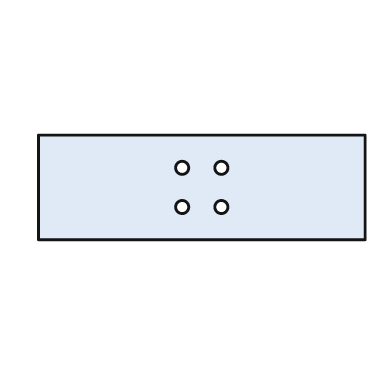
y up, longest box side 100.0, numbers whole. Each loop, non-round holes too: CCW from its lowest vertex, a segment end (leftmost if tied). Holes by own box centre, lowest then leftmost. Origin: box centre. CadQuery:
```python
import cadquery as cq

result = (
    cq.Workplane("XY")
    .moveTo(-50.0, -16.0)
    .lineTo(50.0, -16.0)
    .lineTo(50.0, 16.0)
    .lineTo(-50.0, 16.0)
    .close()
    .moveTo(-6.0, -6.0)
    .circle(2.0)
    .moveTo(6.0, -6.0)
    .circle(2.0)
    .moveTo(-6.0, 6.0)
    .circle(2.0)
    .moveTo(6.0, 6.0)
    .circle(2.0)
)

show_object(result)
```